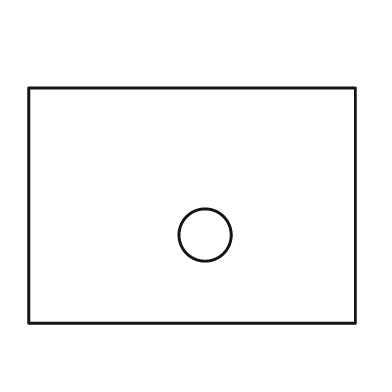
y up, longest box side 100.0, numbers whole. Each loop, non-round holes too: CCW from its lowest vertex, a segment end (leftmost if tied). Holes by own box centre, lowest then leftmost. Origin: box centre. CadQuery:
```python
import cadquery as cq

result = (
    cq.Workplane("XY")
    .moveTo(-50.0, -36.0)
    .lineTo(50.0, -36.0)
    .lineTo(50.0, 36.0)
    .lineTo(-50.0, 36.0)
    .close()
    .moveTo(4.0, -9.0)
    .circle(8.0)
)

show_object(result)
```